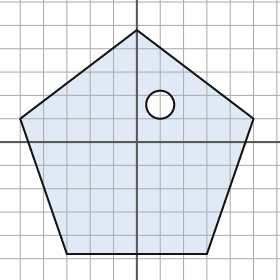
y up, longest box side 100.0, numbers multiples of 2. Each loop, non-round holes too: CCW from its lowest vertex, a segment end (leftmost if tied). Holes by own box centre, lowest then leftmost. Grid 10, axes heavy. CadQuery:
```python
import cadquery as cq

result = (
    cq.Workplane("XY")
    .moveTo(-30.0, -48.0)
    .lineTo(30.0, -48.0)
    .lineTo(50.0, 10.0)
    .lineTo(0.0, 48.0)
    .lineTo(-50.0, 10.0)
    .close()
    .moveTo(10.0, 16.0)
    .circle(6.0)
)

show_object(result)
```